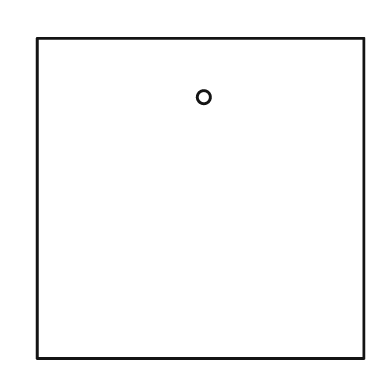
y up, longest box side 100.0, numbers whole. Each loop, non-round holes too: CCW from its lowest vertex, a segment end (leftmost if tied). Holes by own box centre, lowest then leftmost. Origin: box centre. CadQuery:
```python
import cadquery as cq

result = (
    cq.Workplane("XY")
    .moveTo(-50.0, -49.0)
    .lineTo(50.0, -49.0)
    .lineTo(50.0, 49.0)
    .lineTo(-50.0, 49.0)
    .close()
    .moveTo(1.0, 31.0)
    .circle(2.0)
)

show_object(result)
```